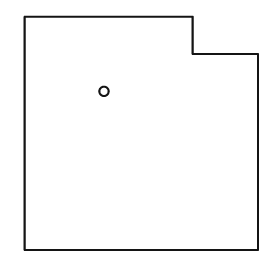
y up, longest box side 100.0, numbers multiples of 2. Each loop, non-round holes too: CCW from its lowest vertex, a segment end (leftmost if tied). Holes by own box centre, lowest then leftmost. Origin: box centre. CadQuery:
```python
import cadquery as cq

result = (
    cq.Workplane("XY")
    .moveTo(-50.0, -50.0)
    .lineTo(50.0, -50.0)
    .lineTo(50.0, 34.0)
    .lineTo(22.0, 34.0)
    .lineTo(22.0, 50.0)
    .lineTo(-50.0, 50.0)
    .close()
    .moveTo(-16.0, 18.0)
    .circle(2.0)
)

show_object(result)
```